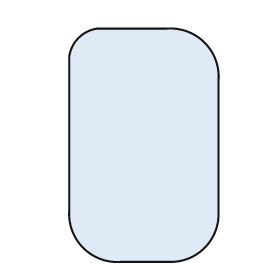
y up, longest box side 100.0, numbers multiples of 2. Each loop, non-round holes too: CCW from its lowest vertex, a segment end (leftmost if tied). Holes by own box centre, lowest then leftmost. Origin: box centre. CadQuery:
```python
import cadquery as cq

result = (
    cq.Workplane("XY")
    .moveTo(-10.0, -50.0)
    .lineTo(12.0, -50.0)
    .threePointArc((26.0, -44.0), (32.0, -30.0))
    .lineTo(32.0, 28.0)
    .threePointArc((26.0, 44.0), (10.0, 50.0))
    .lineTo(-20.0, 50.0)
    .threePointArc((-28.0, 46.0), (-32.0, 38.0))
    .lineTo(-32.0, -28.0)
    .threePointArc((-26.0, -44.0), (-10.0, -50.0))
    .close()
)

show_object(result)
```